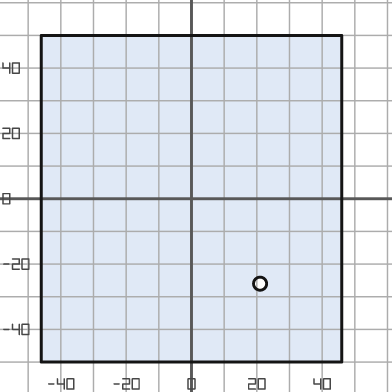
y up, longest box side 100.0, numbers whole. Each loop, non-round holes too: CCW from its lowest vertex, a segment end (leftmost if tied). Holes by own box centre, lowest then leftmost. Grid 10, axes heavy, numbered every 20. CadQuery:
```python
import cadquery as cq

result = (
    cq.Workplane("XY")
    .moveTo(-46.0, -50.0)
    .lineTo(46.0, -50.0)
    .lineTo(46.0, 50.0)
    .lineTo(-46.0, 50.0)
    .close()
    .moveTo(21.0, -26.0)
    .circle(2.0)
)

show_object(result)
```